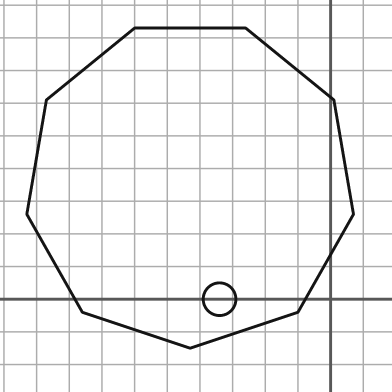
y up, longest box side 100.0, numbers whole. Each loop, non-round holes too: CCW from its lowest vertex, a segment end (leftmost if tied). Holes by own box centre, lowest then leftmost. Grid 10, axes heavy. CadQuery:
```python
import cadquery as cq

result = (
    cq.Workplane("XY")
    .moveTo(-43.0, -15.0)
    .lineTo(-10.0, -4.0)
    .lineTo(7.0, 26.0)
    .lineTo(1.0, 61.0)
    .lineTo(-26.0, 83.0)
    .lineTo(-60.0, 83.0)
    .lineTo(-87.0, 61.0)
    .lineTo(-93.0, 26.0)
    .lineTo(-76.0, -4.0)
    .close()
    .moveTo(-34.0, 0.0)
    .circle(5.0)
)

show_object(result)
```